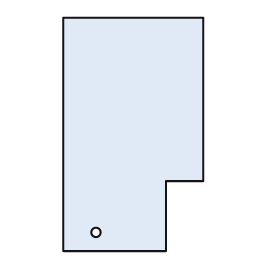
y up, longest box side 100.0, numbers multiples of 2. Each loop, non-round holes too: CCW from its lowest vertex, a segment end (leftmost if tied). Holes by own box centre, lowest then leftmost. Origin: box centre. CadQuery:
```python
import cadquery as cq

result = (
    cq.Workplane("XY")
    .moveTo(-30.0, -50.0)
    .lineTo(14.0, -50.0)
    .lineTo(14.0, -20.0)
    .lineTo(30.0, -20.0)
    .lineTo(30.0, 50.0)
    .lineTo(-30.0, 50.0)
    .close()
    .moveTo(-16.0, -42.0)
    .circle(2.0)
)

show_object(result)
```